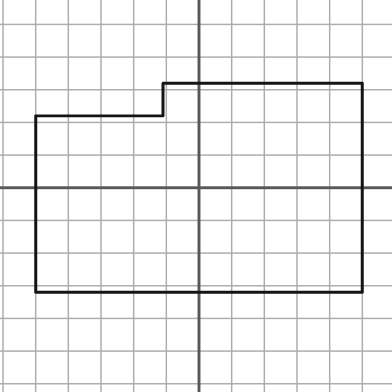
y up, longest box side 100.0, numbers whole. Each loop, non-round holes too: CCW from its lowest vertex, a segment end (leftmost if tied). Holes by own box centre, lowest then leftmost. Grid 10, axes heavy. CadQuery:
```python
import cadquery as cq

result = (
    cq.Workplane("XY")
    .moveTo(-50.0, -32.0)
    .lineTo(50.0, -32.0)
    .lineTo(50.0, 32.0)
    .lineTo(-11.0, 32.0)
    .lineTo(-11.0, 22.0)
    .lineTo(-50.0, 22.0)
    .close()
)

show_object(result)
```